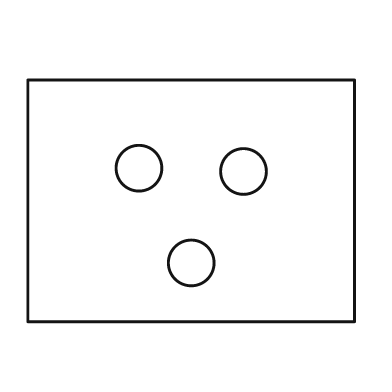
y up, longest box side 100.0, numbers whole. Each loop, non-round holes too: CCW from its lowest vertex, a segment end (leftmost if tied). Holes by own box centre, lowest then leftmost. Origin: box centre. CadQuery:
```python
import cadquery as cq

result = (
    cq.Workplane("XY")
    .moveTo(-50.0, -37.0)
    .lineTo(50.0, -37.0)
    .lineTo(50.0, 37.0)
    .lineTo(-50.0, 37.0)
    .close()
    .moveTo(0.0, -19.0)
    .circle(7.0)
    .moveTo(16.0, 9.0)
    .circle(7.0)
    .moveTo(-16.0, 10.0)
    .circle(7.0)
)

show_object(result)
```